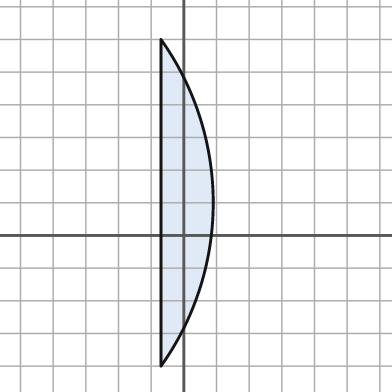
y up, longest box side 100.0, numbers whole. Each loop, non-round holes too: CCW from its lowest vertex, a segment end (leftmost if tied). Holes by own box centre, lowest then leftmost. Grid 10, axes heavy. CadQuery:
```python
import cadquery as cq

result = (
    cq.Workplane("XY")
    .moveTo(-7.0, -40.0)
    .threePointArc((9.0, 10.0), (-7.0, 60.0))
    .close()
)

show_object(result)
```